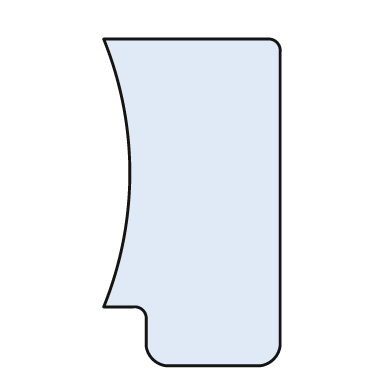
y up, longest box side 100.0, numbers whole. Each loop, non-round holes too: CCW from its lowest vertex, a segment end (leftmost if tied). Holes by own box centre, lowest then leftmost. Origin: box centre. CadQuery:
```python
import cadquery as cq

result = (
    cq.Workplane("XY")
    .moveTo(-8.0, -50.0)
    .lineTo(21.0, -50.0)
    .threePointArc((25.0, -48.0), (27.0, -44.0))
    .lineTo(27.0, 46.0)
    .threePointArc((26.0, 49.0), (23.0, 50.0))
    .lineTo(-27.0, 50.0)
    .threePointArc((-19.0, 9.0), (-27.0, -32.0))
    .lineTo(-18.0, -32.0)
    .threePointArc((-15.0, -33.0), (-14.0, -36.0))
    .lineTo(-14.0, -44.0)
    .threePointArc((-12.0, -48.0), (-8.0, -50.0))
    .close()
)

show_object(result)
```